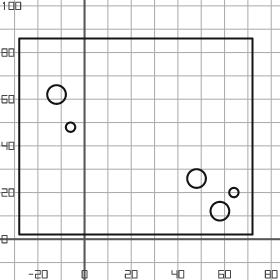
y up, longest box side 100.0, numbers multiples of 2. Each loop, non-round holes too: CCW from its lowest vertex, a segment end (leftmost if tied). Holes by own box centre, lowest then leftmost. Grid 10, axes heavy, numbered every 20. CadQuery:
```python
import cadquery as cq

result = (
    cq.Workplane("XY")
    .moveTo(-28.0, 2.0)
    .lineTo(72.0, 2.0)
    .lineTo(72.0, 86.0)
    .lineTo(-28.0, 86.0)
    .close()
    .moveTo(58.0, 12.0)
    .circle(4.0)
    .moveTo(64.0, 20.0)
    .circle(2.0)
    .moveTo(48.0, 26.0)
    .circle(4.0)
    .moveTo(-6.0, 48.0)
    .circle(2.0)
    .moveTo(-12.0, 62.0)
    .circle(4.0)
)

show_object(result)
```